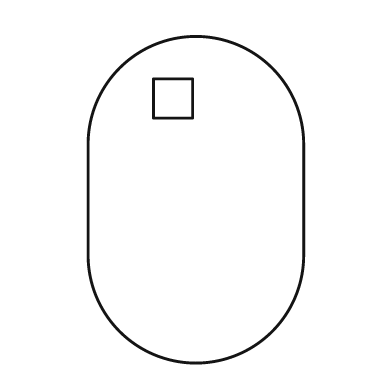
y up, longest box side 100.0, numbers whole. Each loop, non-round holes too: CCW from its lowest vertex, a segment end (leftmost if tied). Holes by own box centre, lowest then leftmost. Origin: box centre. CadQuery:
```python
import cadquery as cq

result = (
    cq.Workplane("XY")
    .moveTo(-33.0, -17.0)
    .threePointArc((0.0, -50.0), (33.0, -17.0))
    .lineTo(33.0, 17.0)
    .threePointArc((0.0, 50.0), (-33.0, 17.0))
    .close()
    .moveTo(-13.0, 25.0)
    .lineTo(-1.0, 25.0)
    .lineTo(-1.0, 37.0)
    .lineTo(-13.0, 37.0)
    .close()
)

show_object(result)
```